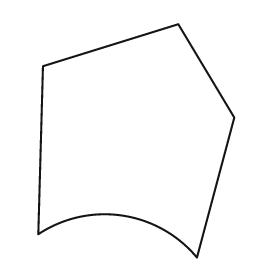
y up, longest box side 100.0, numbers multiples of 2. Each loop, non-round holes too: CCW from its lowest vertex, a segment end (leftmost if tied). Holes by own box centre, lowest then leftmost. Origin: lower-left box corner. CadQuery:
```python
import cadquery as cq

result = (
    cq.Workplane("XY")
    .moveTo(68.0, 0.0)
    .lineTo(84.0, 60.0)
    .lineTo(60.0, 100.0)
    .lineTo(2.0, 82.0)
    .lineTo(0.0, 10.0)
    .threePointArc((36.0, 18.0), (68.0, 0.0))
    .close()
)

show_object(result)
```